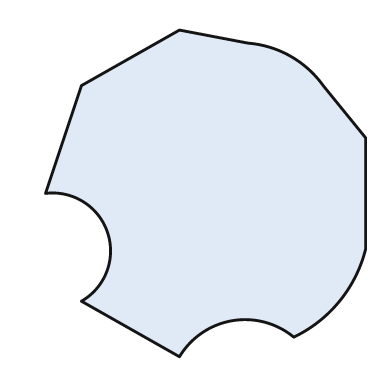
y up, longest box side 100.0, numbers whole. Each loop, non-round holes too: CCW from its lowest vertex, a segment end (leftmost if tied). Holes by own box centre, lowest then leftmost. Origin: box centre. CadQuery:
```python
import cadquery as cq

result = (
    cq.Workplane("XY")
    .moveTo(-8.0, -50.0)
    .threePointArc((8.0, -39.0), (27.0, -44.0))
    .threePointArc((41.0, -33.0), (49.0, -17.0))
    .lineTo(49.0, 17.0)
    .lineTo(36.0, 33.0)
    .threePointArc((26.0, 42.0), (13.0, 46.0))
    .lineTo(-8.0, 50.0)
    .lineTo(-38.0, 33.0)
    .lineTo(-49.0, 0.0)
    .threePointArc((-30.0, -12.0), (-38.0, -33.0))
    .close()
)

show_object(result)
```